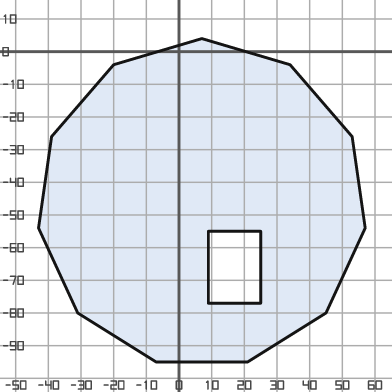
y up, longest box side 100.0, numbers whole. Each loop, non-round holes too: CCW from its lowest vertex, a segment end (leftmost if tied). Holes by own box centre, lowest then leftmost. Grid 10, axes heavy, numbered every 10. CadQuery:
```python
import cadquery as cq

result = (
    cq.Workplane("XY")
    .moveTo(-7.0, -95.0)
    .lineTo(21.0, -95.0)
    .lineTo(45.0, -80.0)
    .lineTo(57.0, -54.0)
    .lineTo(53.0, -26.0)
    .lineTo(34.0, -4.0)
    .lineTo(7.0, 4.0)
    .lineTo(-20.0, -4.0)
    .lineTo(-39.0, -26.0)
    .lineTo(-43.0, -54.0)
    .lineTo(-31.0, -80.0)
    .close()
    .moveTo(9.0, -77.0)
    .lineTo(25.0, -77.0)
    .lineTo(25.0, -55.0)
    .lineTo(9.0, -55.0)
    .close()
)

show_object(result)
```